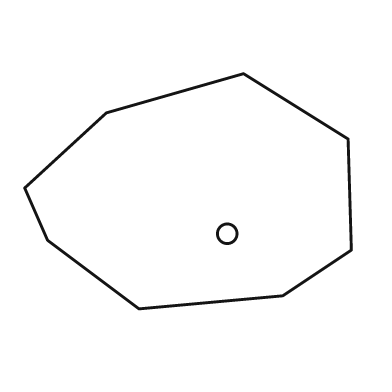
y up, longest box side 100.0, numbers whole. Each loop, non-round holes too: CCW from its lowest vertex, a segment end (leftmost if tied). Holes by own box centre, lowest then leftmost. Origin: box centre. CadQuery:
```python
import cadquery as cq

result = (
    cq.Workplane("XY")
    .moveTo(-15.0, -36.0)
    .lineTo(29.0, -32.0)
    .lineTo(50.0, -18.0)
    .lineTo(49.0, 16.0)
    .lineTo(17.0, 36.0)
    .lineTo(-25.0, 24.0)
    .lineTo(-50.0, 1.0)
    .lineTo(-43.0, -15.0)
    .close()
    .moveTo(12.0, -13.0)
    .circle(3.0)
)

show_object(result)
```